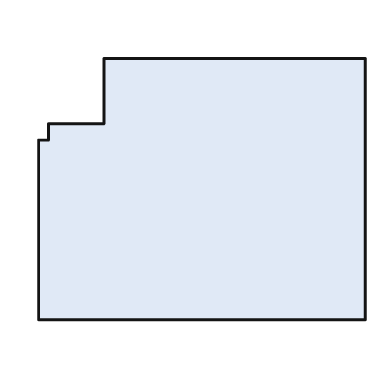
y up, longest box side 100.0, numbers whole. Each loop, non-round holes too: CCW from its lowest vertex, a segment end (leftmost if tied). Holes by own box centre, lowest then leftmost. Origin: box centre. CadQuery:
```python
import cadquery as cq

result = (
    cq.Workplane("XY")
    .moveTo(-50.0, -40.0)
    .lineTo(50.0, -40.0)
    .lineTo(50.0, 40.0)
    .lineTo(-30.0, 40.0)
    .lineTo(-30.0, 20.0)
    .lineTo(-47.0, 20.0)
    .lineTo(-47.0, 15.0)
    .lineTo(-50.0, 15.0)
    .close()
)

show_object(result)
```